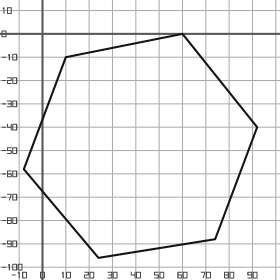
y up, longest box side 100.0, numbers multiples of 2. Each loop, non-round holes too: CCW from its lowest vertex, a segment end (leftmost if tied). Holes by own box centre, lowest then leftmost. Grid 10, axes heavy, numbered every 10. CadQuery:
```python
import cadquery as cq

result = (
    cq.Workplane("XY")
    .moveTo(24.0, -96.0)
    .lineTo(74.0, -88.0)
    .lineTo(92.0, -40.0)
    .lineTo(60.0, 0.0)
    .lineTo(10.0, -10.0)
    .lineTo(-8.0, -58.0)
    .close()
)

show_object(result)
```